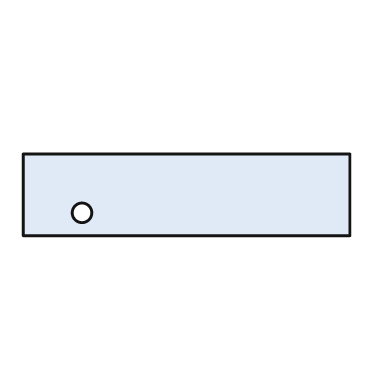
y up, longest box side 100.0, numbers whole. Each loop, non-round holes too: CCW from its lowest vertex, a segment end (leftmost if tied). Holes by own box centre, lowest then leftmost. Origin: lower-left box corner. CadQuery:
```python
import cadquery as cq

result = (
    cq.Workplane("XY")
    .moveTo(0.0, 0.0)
    .lineTo(100.0, 0.0)
    .lineTo(100.0, 25.0)
    .lineTo(0.0, 25.0)
    .close()
    .moveTo(18.0, 7.0)
    .circle(3.0)
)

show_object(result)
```